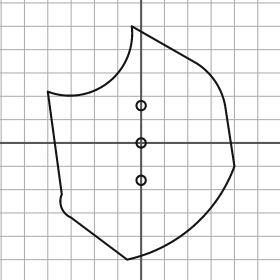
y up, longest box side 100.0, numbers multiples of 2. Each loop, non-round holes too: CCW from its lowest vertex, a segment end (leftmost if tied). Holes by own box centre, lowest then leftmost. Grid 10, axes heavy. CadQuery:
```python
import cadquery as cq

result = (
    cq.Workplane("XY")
    .moveTo(-6.0, -50.0)
    .threePointArc((22.0, -36.0), (40.0, -10.0))
    .lineTo(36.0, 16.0)
    .threePointArc((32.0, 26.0), (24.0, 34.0))
    .lineTo(-4.0, 50.0)
    .threePointArc((-14.0, 26.0), (-40.0, 22.0))
    .lineTo(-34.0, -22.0)
    .threePointArc((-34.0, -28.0), (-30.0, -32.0))
    .close()
    .moveTo(0.0, -16.0)
    .circle(2.0)
    .moveTo(0.0, 0.0)
    .circle(2.0)
    .moveTo(0.0, 16.0)
    .circle(2.0)
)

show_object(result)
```